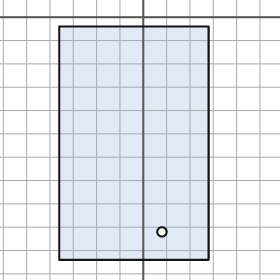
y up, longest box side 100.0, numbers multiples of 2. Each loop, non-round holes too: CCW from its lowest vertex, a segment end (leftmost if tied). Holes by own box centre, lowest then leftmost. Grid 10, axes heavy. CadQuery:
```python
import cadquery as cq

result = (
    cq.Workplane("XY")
    .moveTo(-36.0, -104.0)
    .lineTo(28.0, -104.0)
    .lineTo(28.0, -4.0)
    .lineTo(-36.0, -4.0)
    .close()
    .moveTo(8.0, -92.0)
    .circle(2.0)
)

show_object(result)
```